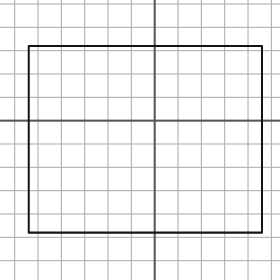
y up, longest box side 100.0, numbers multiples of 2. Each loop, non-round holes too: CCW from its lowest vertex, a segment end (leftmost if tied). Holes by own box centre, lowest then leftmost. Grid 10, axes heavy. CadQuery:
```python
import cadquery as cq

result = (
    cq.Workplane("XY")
    .moveTo(-54.0, -48.0)
    .lineTo(46.0, -48.0)
    .lineTo(46.0, 32.0)
    .lineTo(-54.0, 32.0)
    .close()
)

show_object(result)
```